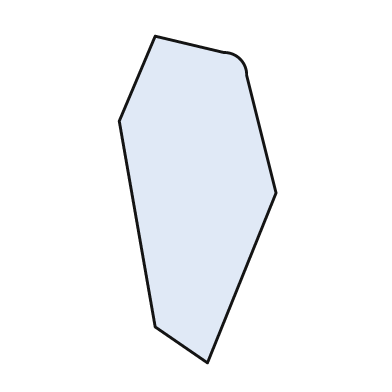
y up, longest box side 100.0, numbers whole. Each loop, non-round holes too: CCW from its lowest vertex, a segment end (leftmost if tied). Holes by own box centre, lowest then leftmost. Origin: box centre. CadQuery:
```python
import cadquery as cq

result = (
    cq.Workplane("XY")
    .moveTo(3.0, -50.0)
    .lineTo(24.0, 2.0)
    .lineTo(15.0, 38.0)
    .threePointArc((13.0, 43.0), (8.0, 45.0))
    .lineTo(-13.0, 50.0)
    .lineTo(-24.0, 24.0)
    .lineTo(-13.0, -39.0)
    .close()
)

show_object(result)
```